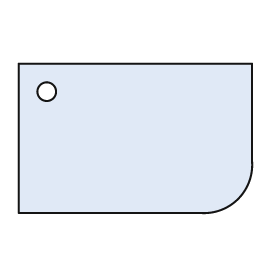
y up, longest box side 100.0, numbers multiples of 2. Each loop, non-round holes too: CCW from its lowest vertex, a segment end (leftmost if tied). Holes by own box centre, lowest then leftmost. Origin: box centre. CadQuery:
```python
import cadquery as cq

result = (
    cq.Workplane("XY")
    .moveTo(-50.0, -32.0)
    .lineTo(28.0, -32.0)
    .threePointArc((44.0, -26.0), (50.0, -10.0))
    .lineTo(50.0, 32.0)
    .lineTo(-50.0, 32.0)
    .close()
    .moveTo(-38.0, 20.0)
    .circle(4.0)
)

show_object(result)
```